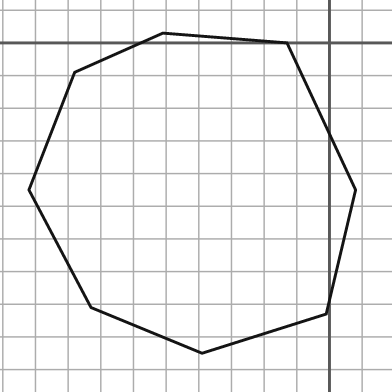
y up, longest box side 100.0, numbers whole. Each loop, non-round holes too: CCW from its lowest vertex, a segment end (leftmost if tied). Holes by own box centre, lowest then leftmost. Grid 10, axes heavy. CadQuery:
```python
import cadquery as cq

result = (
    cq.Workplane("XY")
    .moveTo(-39.0, -95.0)
    .lineTo(-1.0, -83.0)
    .lineTo(8.0, -45.0)
    .lineTo(-13.0, 0.0)
    .lineTo(-51.0, 3.0)
    .lineTo(-78.0, -9.0)
    .lineTo(-92.0, -45.0)
    .lineTo(-73.0, -81.0)
    .close()
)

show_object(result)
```